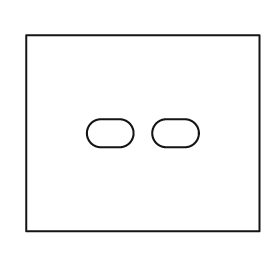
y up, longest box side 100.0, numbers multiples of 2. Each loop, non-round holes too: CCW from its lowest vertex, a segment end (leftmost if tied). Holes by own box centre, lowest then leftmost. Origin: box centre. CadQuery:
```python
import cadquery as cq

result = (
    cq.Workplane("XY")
    .moveTo(-50.0, -42.0)
    .lineTo(50.0, -42.0)
    .lineTo(50.0, 42.0)
    .lineTo(-50.0, 42.0)
    .close()
    .moveTo(-18.0, -6.0)
    .lineTo(-10.0, -6.0)
    .threePointArc((-4.0, 0.0), (-10.0, 6.0))
    .lineTo(-18.0, 6.0)
    .threePointArc((-24.0, 0.0), (-18.0, -6.0))
    .close()
    .moveTo(10.0, -6.0)
    .lineTo(18.0, -6.0)
    .threePointArc((24.0, 0.0), (18.0, 6.0))
    .lineTo(10.0, 6.0)
    .threePointArc((4.0, 0.0), (10.0, -6.0))
    .close()
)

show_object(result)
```